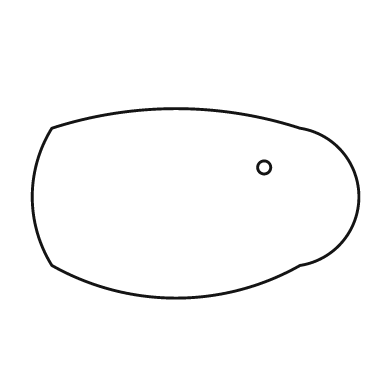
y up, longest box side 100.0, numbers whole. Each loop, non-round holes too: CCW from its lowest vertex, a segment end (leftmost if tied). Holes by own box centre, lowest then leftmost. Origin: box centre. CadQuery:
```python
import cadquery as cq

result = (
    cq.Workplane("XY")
    .moveTo(-44.0, -19.0)
    .threePointArc((-6.0, -29.0), (32.0, -19.0))
    .threePointArc((50.0, 2.0), (32.0, 23.0))
    .threePointArc((-6.0, 29.0), (-44.0, 23.0))
    .threePointArc((-50.0, 2.0), (-44.0, -19.0))
    .close()
    .moveTo(21.0, 11.0)
    .circle(2.0)
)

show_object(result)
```